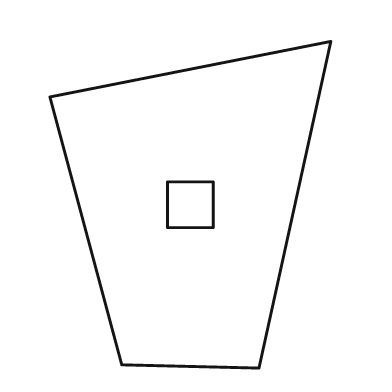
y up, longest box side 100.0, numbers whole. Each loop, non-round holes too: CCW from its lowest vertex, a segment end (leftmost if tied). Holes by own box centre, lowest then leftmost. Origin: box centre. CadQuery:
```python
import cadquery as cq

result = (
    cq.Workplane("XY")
    .moveTo(21.0, -50.0)
    .lineTo(43.0, 50.0)
    .lineTo(-43.0, 33.0)
    .lineTo(-21.0, -49.0)
    .close()
    .moveTo(-7.0, -7.0)
    .lineTo(7.0, -7.0)
    .lineTo(7.0, 7.0)
    .lineTo(-7.0, 7.0)
    .close()
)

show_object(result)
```